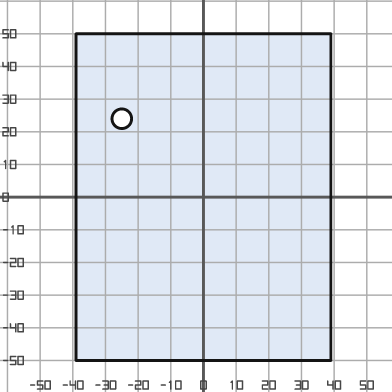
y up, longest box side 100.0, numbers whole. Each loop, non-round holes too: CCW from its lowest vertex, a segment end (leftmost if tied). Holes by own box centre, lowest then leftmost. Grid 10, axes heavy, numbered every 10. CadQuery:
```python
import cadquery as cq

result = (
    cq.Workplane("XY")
    .moveTo(-39.0, -50.0)
    .lineTo(39.0, -50.0)
    .lineTo(39.0, 50.0)
    .lineTo(-39.0, 50.0)
    .close()
    .moveTo(-25.0, 24.0)
    .circle(3.0)
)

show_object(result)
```